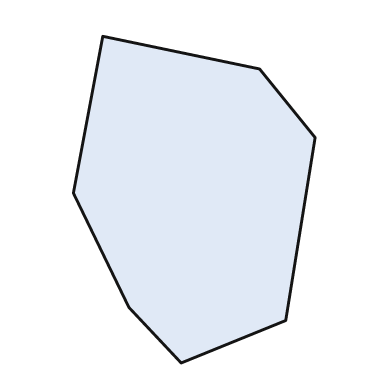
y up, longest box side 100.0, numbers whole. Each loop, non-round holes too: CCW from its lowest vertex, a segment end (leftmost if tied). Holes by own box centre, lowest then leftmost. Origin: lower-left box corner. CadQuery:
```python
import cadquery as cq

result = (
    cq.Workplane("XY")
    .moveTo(33.0, 0.0)
    .lineTo(65.0, 13.0)
    .lineTo(74.0, 69.0)
    .lineTo(57.0, 90.0)
    .lineTo(9.0, 100.0)
    .lineTo(0.0, 52.0)
    .lineTo(17.0, 17.0)
    .close()
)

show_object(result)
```